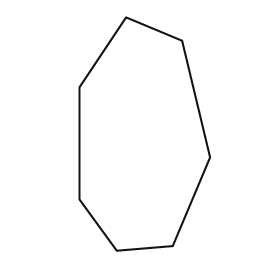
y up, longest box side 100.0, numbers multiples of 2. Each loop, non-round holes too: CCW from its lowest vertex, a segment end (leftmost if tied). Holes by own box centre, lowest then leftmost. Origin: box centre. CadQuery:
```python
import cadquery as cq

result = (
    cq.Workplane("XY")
    .moveTo(-12.0, -50.0)
    .lineTo(12.0, -48.0)
    .lineTo(28.0, -10.0)
    .lineTo(16.0, 40.0)
    .lineTo(-8.0, 50.0)
    .lineTo(-28.0, 20.0)
    .lineTo(-28.0, -28.0)
    .close()
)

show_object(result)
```